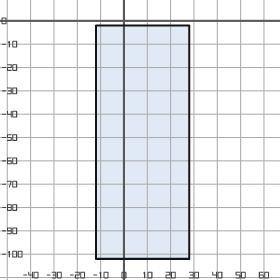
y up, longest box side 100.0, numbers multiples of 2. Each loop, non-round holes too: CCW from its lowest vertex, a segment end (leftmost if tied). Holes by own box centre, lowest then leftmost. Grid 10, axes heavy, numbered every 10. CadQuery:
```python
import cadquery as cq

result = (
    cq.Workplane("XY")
    .moveTo(-12.0, -102.0)
    .lineTo(28.0, -102.0)
    .lineTo(28.0, -2.0)
    .lineTo(-12.0, -2.0)
    .close()
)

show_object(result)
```